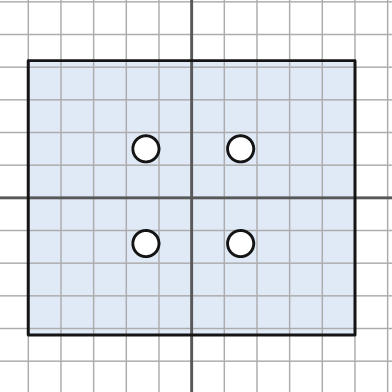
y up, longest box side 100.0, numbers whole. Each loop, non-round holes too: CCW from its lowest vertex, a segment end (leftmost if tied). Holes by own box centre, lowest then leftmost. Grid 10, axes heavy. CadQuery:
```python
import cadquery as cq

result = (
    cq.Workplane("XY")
    .moveTo(-50.0, -42.0)
    .lineTo(50.0, -42.0)
    .lineTo(50.0, 42.0)
    .lineTo(-50.0, 42.0)
    .close()
    .moveTo(-14.0, -14.0)
    .circle(4.0)
    .moveTo(15.0, -14.0)
    .circle(4.0)
    .moveTo(-14.0, 15.0)
    .circle(4.0)
    .moveTo(15.0, 15.0)
    .circle(4.0)
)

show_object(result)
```